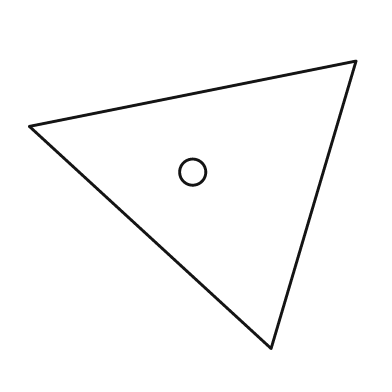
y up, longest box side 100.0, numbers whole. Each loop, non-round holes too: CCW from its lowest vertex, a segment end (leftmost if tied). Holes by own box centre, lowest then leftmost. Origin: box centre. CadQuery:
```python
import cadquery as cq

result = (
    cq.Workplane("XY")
    .moveTo(24.0, -44.0)
    .lineTo(50.0, 44.0)
    .lineTo(-50.0, 24.0)
    .close()
    .moveTo(0.0, 10.0)
    .circle(4.0)
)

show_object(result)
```